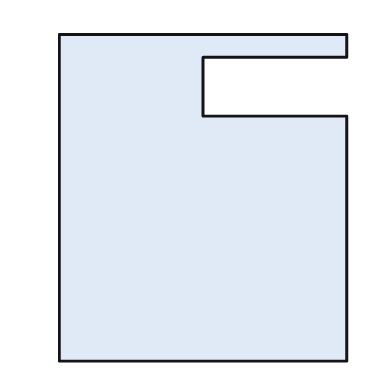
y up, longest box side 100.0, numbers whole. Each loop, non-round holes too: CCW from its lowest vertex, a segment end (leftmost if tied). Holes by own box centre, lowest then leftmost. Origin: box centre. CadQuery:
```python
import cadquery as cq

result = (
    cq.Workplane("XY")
    .moveTo(-44.0, -50.0)
    .lineTo(44.0, -50.0)
    .lineTo(44.0, 25.0)
    .lineTo(0.0, 25.0)
    .lineTo(0.0, 43.0)
    .lineTo(44.0, 43.0)
    .lineTo(44.0, 50.0)
    .lineTo(-44.0, 50.0)
    .close()
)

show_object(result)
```